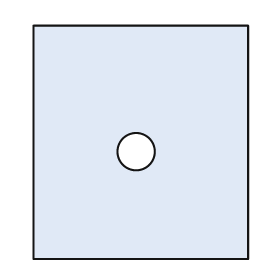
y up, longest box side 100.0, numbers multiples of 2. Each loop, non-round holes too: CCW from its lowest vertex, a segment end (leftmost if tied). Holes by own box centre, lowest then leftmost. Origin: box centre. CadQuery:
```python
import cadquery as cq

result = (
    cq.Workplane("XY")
    .moveTo(-46.0, -50.0)
    .lineTo(46.0, -50.0)
    .lineTo(46.0, 50.0)
    .lineTo(-46.0, 50.0)
    .close()
    .moveTo(-2.0, -4.0)
    .circle(8.0)
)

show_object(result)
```